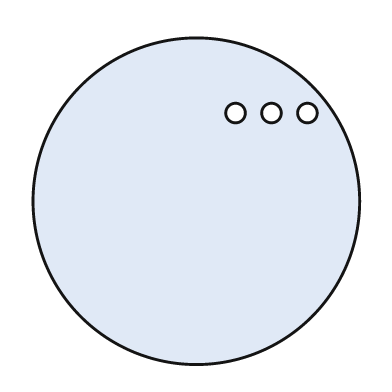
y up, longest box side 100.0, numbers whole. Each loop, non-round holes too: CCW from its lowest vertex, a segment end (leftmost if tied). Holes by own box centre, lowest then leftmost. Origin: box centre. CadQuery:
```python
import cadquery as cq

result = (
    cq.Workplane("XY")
    .moveTo(0.0, 0.0)
    .circle(50.0)
    .moveTo(12.0, 27.0)
    .circle(3.0)
    .moveTo(23.0, 27.0)
    .circle(3.0)
    .moveTo(34.0, 27.0)
    .circle(3.0)
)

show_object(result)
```